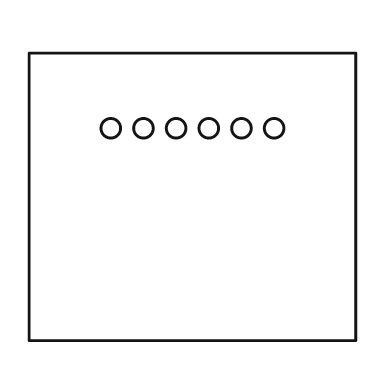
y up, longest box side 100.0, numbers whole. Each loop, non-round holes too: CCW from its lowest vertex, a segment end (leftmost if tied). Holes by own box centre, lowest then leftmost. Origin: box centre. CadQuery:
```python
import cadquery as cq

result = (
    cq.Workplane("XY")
    .moveTo(-50.0, -44.0)
    .lineTo(50.0, -44.0)
    .lineTo(50.0, 44.0)
    .lineTo(-50.0, 44.0)
    .close()
    .moveTo(-25.0, 21.0)
    .circle(3.0)
    .moveTo(-15.0, 21.0)
    .circle(3.0)
    .moveTo(-5.0, 21.0)
    .circle(3.0)
    .moveTo(5.0, 21.0)
    .circle(3.0)
    .moveTo(15.0, 21.0)
    .circle(3.0)
    .moveTo(25.0, 21.0)
    .circle(3.0)
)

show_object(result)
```